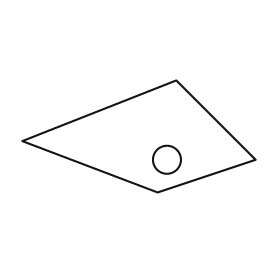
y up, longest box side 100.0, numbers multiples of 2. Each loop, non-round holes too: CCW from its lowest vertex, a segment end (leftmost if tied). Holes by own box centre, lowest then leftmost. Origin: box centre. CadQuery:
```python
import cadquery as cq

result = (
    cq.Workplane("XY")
    .moveTo(8.0, -24.0)
    .lineTo(50.0, -10.0)
    .lineTo(16.0, 24.0)
    .lineTo(-50.0, -2.0)
    .close()
    .moveTo(12.0, -10.0)
    .circle(6.0)
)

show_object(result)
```